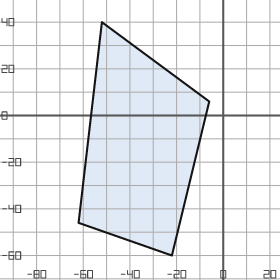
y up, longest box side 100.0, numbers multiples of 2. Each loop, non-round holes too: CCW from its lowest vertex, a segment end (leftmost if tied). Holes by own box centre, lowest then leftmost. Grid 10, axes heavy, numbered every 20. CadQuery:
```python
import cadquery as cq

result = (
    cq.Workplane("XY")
    .moveTo(-22.0, -60.0)
    .lineTo(-6.0, 6.0)
    .lineTo(-52.0, 40.0)
    .lineTo(-62.0, -46.0)
    .close()
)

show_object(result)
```